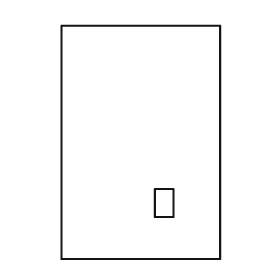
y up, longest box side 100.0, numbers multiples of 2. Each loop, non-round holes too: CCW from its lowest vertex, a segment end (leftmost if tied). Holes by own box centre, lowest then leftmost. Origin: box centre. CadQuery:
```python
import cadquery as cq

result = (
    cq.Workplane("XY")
    .moveTo(-34.0, -50.0)
    .lineTo(34.0, -50.0)
    .lineTo(34.0, 50.0)
    .lineTo(-34.0, 50.0)
    .close()
    .moveTo(6.0, -32.0)
    .lineTo(14.0, -32.0)
    .lineTo(14.0, -20.0)
    .lineTo(6.0, -20.0)
    .close()
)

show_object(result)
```